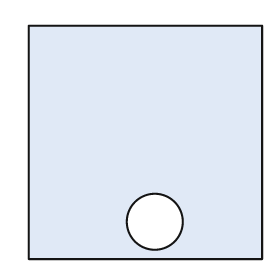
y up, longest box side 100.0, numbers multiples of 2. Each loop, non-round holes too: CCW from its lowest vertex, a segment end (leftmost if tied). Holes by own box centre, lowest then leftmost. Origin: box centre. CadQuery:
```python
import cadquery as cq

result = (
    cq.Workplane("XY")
    .moveTo(-50.0, -50.0)
    .lineTo(50.0, -50.0)
    .lineTo(50.0, 50.0)
    .lineTo(-50.0, 50.0)
    .close()
    .moveTo(4.0, -34.0)
    .circle(12.0)
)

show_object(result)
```